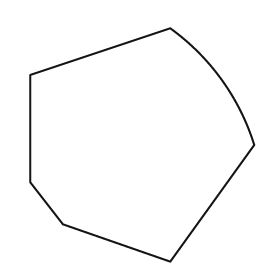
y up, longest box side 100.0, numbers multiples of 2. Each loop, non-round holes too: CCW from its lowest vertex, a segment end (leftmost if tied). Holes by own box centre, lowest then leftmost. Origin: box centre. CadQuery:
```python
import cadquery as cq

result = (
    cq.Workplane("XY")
    .moveTo(12.0, -50.0)
    .lineTo(48.0, 0.0)
    .threePointArc((34.0, 28.0), (12.0, 50.0))
    .lineTo(-48.0, 30.0)
    .lineTo(-48.0, -16.0)
    .lineTo(-34.0, -34.0)
    .close()
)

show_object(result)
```